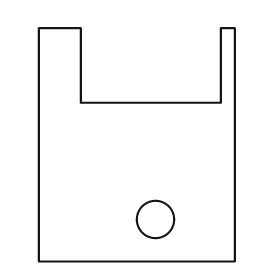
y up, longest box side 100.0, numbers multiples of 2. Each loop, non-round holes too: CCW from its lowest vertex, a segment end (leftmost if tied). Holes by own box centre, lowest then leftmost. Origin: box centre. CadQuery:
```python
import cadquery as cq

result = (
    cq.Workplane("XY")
    .moveTo(-42.0, -50.0)
    .lineTo(42.0, -50.0)
    .lineTo(42.0, 50.0)
    .lineTo(36.0, 50.0)
    .lineTo(36.0, 18.0)
    .lineTo(-24.0, 18.0)
    .lineTo(-24.0, 50.0)
    .lineTo(-42.0, 50.0)
    .close()
    .moveTo(8.0, -32.0)
    .circle(8.0)
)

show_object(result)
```